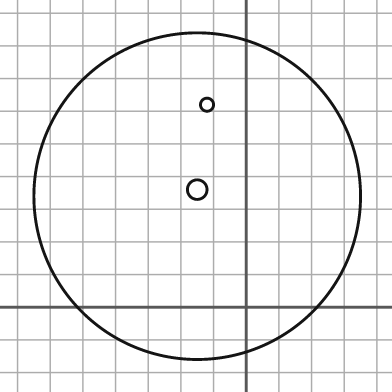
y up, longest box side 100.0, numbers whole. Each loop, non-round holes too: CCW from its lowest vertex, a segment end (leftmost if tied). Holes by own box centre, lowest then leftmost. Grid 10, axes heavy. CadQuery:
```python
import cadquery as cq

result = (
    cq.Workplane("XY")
    .moveTo(-15.0, 34.0)
    .circle(50.0)
    .moveTo(-15.0, 36.0)
    .circle(3.0)
    .moveTo(-12.0, 62.0)
    .circle(2.0)
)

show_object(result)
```